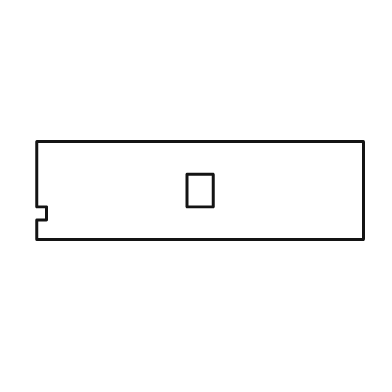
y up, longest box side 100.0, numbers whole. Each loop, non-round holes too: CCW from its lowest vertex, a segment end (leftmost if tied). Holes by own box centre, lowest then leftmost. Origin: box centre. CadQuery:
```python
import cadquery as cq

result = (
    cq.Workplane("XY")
    .moveTo(-50.0, -15.0)
    .lineTo(50.0, -15.0)
    .lineTo(50.0, 15.0)
    .lineTo(-50.0, 15.0)
    .lineTo(-50.0, -5.0)
    .lineTo(-47.0, -5.0)
    .lineTo(-47.0, -9.0)
    .lineTo(-50.0, -9.0)
    .close()
    .moveTo(-4.0, -5.0)
    .lineTo(4.0, -5.0)
    .lineTo(4.0, 5.0)
    .lineTo(-4.0, 5.0)
    .close()
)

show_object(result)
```